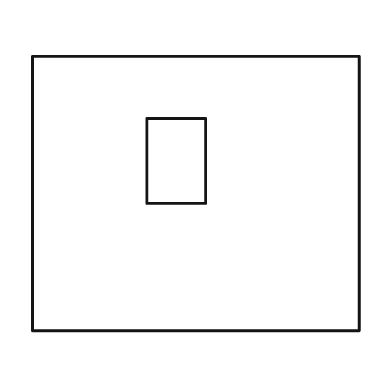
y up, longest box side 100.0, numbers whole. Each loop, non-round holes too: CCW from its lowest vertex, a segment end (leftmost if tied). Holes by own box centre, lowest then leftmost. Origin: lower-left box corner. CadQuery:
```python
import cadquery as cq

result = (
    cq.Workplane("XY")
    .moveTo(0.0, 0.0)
    .lineTo(100.0, 0.0)
    .lineTo(100.0, 84.0)
    .lineTo(0.0, 84.0)
    .close()
    .moveTo(35.0, 39.0)
    .lineTo(53.0, 39.0)
    .lineTo(53.0, 65.0)
    .lineTo(35.0, 65.0)
    .close()
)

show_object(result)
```